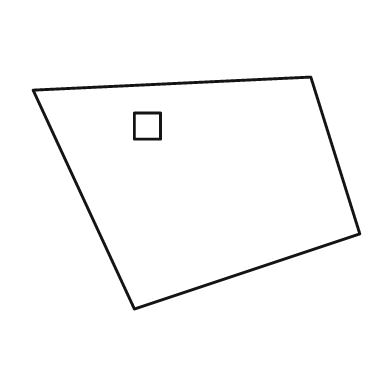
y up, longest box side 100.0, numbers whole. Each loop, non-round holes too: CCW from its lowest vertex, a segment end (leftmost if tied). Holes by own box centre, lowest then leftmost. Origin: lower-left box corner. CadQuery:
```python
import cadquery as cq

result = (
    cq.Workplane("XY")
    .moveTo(31.0, 0.0)
    .lineTo(100.0, 23.0)
    .lineTo(85.0, 71.0)
    .lineTo(0.0, 67.0)
    .close()
    .moveTo(31.0, 52.0)
    .lineTo(39.0, 52.0)
    .lineTo(39.0, 60.0)
    .lineTo(31.0, 60.0)
    .close()
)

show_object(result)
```